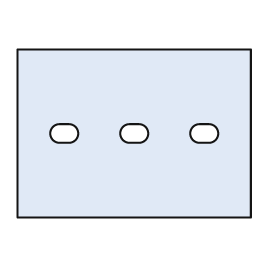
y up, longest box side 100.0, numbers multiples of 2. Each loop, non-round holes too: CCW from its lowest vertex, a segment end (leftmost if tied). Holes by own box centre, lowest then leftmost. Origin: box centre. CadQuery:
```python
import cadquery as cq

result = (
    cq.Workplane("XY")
    .moveTo(-50.0, -36.0)
    .lineTo(50.0, -36.0)
    .lineTo(50.0, 36.0)
    .lineTo(-50.0, 36.0)
    .close()
    .moveTo(-32.0, -4.0)
    .lineTo(-28.0, -4.0)
    .threePointArc((-24.0, 0.0), (-28.0, 4.0))
    .lineTo(-32.0, 4.0)
    .threePointArc((-36.0, 0.0), (-32.0, -4.0))
    .close()
    .moveTo(-2.0, -4.0)
    .lineTo(2.0, -4.0)
    .threePointArc((6.0, 0.0), (2.0, 4.0))
    .lineTo(-2.0, 4.0)
    .threePointArc((-6.0, 0.0), (-2.0, -4.0))
    .close()
    .moveTo(28.0, -4.0)
    .lineTo(32.0, -4.0)
    .threePointArc((36.0, 0.0), (32.0, 4.0))
    .lineTo(28.0, 4.0)
    .threePointArc((24.0, 0.0), (28.0, -4.0))
    .close()
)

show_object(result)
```